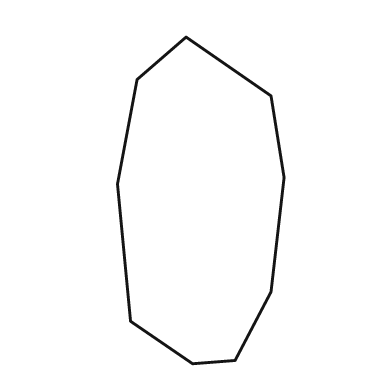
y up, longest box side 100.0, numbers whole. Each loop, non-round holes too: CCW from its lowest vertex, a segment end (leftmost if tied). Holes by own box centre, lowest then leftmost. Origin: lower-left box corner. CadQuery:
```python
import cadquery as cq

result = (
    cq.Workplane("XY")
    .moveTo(23.0, 0.0)
    .lineTo(36.0, 1.0)
    .lineTo(47.0, 22.0)
    .lineTo(51.0, 57.0)
    .lineTo(47.0, 82.0)
    .lineTo(21.0, 100.0)
    .lineTo(6.0, 87.0)
    .lineTo(0.0, 55.0)
    .lineTo(4.0, 13.0)
    .close()
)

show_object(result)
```